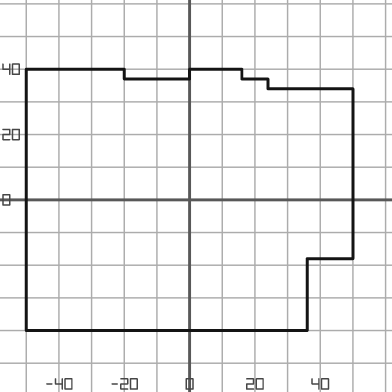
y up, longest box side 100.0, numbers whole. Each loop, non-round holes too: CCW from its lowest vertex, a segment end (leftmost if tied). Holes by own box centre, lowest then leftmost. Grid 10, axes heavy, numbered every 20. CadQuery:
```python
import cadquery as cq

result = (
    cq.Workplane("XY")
    .moveTo(-50.0, -40.0)
    .lineTo(36.0, -40.0)
    .lineTo(36.0, -18.0)
    .lineTo(50.0, -18.0)
    .lineTo(50.0, 34.0)
    .lineTo(24.0, 34.0)
    .lineTo(24.0, 37.0)
    .lineTo(16.0, 37.0)
    .lineTo(16.0, 40.0)
    .lineTo(0.0, 40.0)
    .lineTo(0.0, 37.0)
    .lineTo(-20.0, 37.0)
    .lineTo(-20.0, 40.0)
    .lineTo(-50.0, 40.0)
    .close()
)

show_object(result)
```